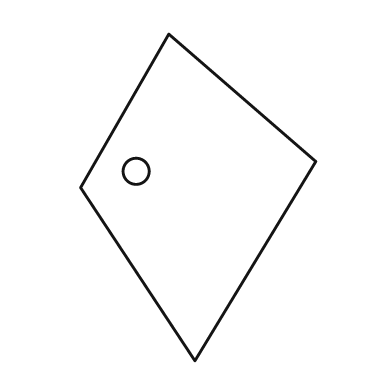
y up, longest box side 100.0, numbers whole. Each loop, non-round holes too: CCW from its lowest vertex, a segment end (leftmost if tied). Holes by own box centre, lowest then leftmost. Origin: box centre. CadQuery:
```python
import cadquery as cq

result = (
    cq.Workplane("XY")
    .moveTo(-1.0, -50.0)
    .lineTo(36.0, 11.0)
    .lineTo(-9.0, 50.0)
    .lineTo(-36.0, 3.0)
    .close()
    .moveTo(-19.0, 8.0)
    .circle(4.0)
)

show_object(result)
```